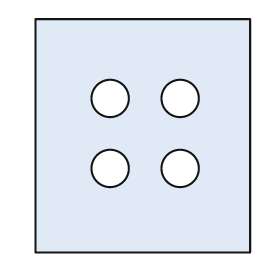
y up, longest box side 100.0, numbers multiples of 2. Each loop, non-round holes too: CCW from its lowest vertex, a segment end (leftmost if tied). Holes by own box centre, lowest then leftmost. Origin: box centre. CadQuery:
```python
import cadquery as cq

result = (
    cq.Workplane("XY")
    .moveTo(-46.0, -50.0)
    .lineTo(46.0, -50.0)
    .lineTo(46.0, 50.0)
    .lineTo(-46.0, 50.0)
    .close()
    .moveTo(-14.0, -14.0)
    .circle(8.0)
    .moveTo(16.0, -14.0)
    .circle(8.0)
    .moveTo(-14.0, 16.0)
    .circle(8.0)
    .moveTo(16.0, 16.0)
    .circle(8.0)
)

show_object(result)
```